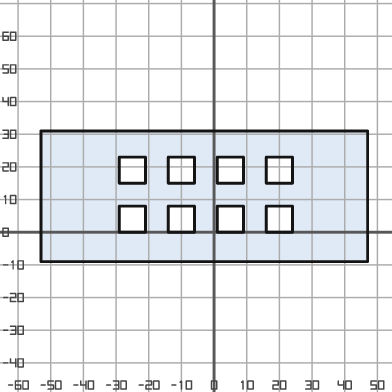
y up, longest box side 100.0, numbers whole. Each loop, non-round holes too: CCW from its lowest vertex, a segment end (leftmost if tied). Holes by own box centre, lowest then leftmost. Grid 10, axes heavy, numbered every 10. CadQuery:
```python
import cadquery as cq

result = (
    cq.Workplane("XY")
    .moveTo(-53.0, -9.0)
    .lineTo(47.0, -9.0)
    .lineTo(47.0, 31.0)
    .lineTo(-53.0, 31.0)
    .close()
    .moveTo(-29.0, 0.0)
    .lineTo(-21.0, 0.0)
    .lineTo(-21.0, 8.0)
    .lineTo(-29.0, 8.0)
    .close()
    .moveTo(-14.0, 0.0)
    .lineTo(-6.0, 0.0)
    .lineTo(-6.0, 8.0)
    .lineTo(-14.0, 8.0)
    .close()
    .moveTo(1.0, 0.0)
    .lineTo(9.0, 0.0)
    .lineTo(9.0, 8.0)
    .lineTo(1.0, 8.0)
    .close()
    .moveTo(16.0, 0.0)
    .lineTo(24.0, 0.0)
    .lineTo(24.0, 8.0)
    .lineTo(16.0, 8.0)
    .close()
    .moveTo(-29.0, 15.0)
    .lineTo(-21.0, 15.0)
    .lineTo(-21.0, 23.0)
    .lineTo(-29.0, 23.0)
    .close()
    .moveTo(-14.0, 15.0)
    .lineTo(-6.0, 15.0)
    .lineTo(-6.0, 23.0)
    .lineTo(-14.0, 23.0)
    .close()
    .moveTo(1.0, 15.0)
    .lineTo(9.0, 15.0)
    .lineTo(9.0, 23.0)
    .lineTo(1.0, 23.0)
    .close()
    .moveTo(16.0, 15.0)
    .lineTo(24.0, 15.0)
    .lineTo(24.0, 23.0)
    .lineTo(16.0, 23.0)
    .close()
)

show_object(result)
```